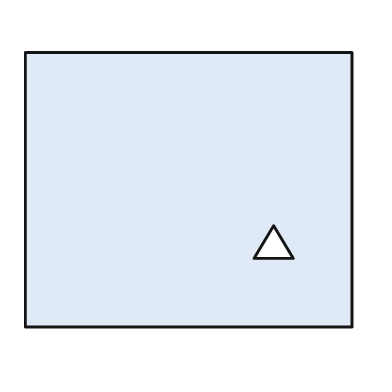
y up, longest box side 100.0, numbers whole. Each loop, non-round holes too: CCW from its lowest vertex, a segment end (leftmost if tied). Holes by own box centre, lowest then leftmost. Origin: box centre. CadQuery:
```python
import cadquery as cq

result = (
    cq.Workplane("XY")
    .moveTo(-50.0, -42.0)
    .lineTo(50.0, -42.0)
    .lineTo(50.0, 42.0)
    .lineTo(-50.0, 42.0)
    .close()
    .moveTo(20.0, -21.0)
    .lineTo(32.0, -21.0)
    .lineTo(26.0, -11.0)
    .close()
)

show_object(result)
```